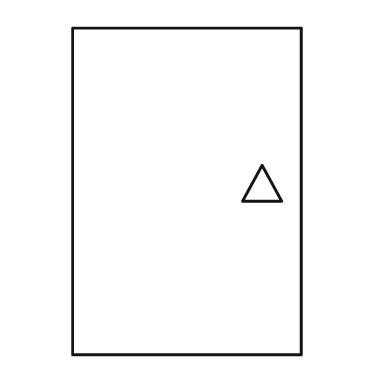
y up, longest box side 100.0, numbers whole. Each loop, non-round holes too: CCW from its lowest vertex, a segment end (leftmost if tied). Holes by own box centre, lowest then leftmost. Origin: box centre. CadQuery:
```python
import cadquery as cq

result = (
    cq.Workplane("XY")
    .moveTo(-35.0, -50.0)
    .lineTo(35.0, -50.0)
    .lineTo(35.0, 50.0)
    .lineTo(-35.0, 50.0)
    .close()
    .moveTo(17.0, -3.0)
    .lineTo(29.0, -3.0)
    .lineTo(23.0, 8.0)
    .close()
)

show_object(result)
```